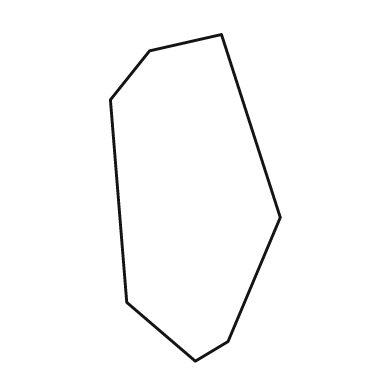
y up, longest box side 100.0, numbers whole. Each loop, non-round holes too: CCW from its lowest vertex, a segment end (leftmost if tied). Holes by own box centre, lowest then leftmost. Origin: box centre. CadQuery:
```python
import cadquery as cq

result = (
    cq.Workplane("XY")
    .moveTo(0.0, -50.0)
    .lineTo(10.0, -44.0)
    .lineTo(26.0, -6.0)
    .lineTo(8.0, 50.0)
    .lineTo(-14.0, 45.0)
    .lineTo(-26.0, 30.0)
    .lineTo(-21.0, -32.0)
    .close()
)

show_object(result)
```